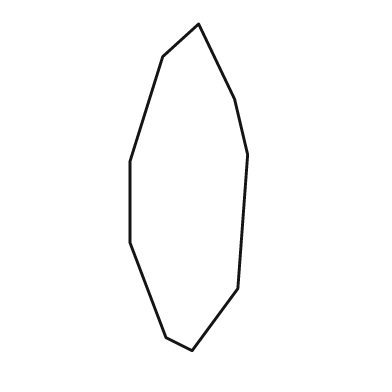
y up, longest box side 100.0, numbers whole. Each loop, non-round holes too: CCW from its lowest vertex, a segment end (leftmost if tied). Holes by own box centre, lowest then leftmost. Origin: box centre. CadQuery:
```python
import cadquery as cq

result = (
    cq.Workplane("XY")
    .moveTo(1.0, -50.0)
    .lineTo(15.0, -31.0)
    .lineTo(18.0, 10.0)
    .lineTo(14.0, 27.0)
    .lineTo(3.0, 50.0)
    .lineTo(-8.0, 40.0)
    .lineTo(-18.0, 8.0)
    .lineTo(-18.0, -17.0)
    .lineTo(-7.0, -46.0)
    .close()
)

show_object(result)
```